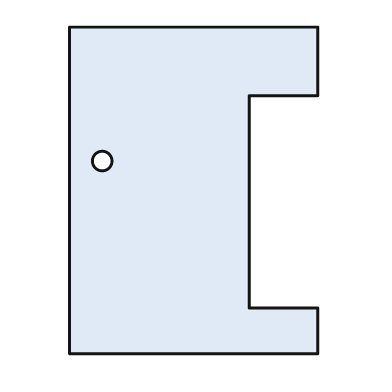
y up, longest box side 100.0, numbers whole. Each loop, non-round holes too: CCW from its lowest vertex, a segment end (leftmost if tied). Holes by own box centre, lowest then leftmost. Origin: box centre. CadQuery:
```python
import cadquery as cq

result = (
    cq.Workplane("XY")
    .moveTo(-38.0, -50.0)
    .lineTo(38.0, -50.0)
    .lineTo(38.0, -36.0)
    .lineTo(17.0, -36.0)
    .lineTo(17.0, 29.0)
    .lineTo(38.0, 29.0)
    .lineTo(38.0, 50.0)
    .lineTo(-38.0, 50.0)
    .close()
    .moveTo(-28.0, 9.0)
    .circle(3.0)
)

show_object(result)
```